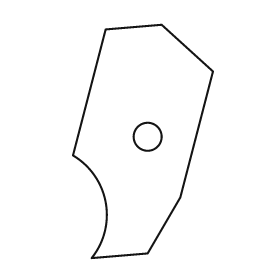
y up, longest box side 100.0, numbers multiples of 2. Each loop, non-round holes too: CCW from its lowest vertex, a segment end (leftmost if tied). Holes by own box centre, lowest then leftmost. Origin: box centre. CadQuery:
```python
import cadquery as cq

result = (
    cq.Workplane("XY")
    .moveTo(-22.0, -50.0)
    .lineTo(2.0, -48.0)
    .lineTo(16.0, -24.0)
    .lineTo(30.0, 30.0)
    .lineTo(8.0, 50.0)
    .lineTo(-16.0, 48.0)
    .lineTo(-30.0, -6.0)
    .threePointArc((-16.0, -26.0), (-22.0, -50.0))
    .close()
    .moveTo(2.0, 2.0)
    .circle(6.0)
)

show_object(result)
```